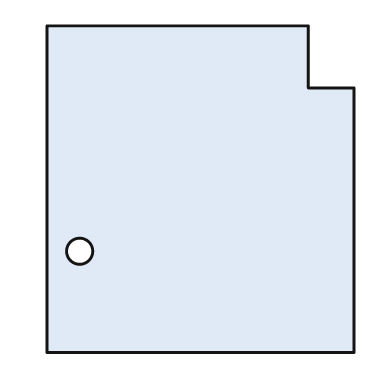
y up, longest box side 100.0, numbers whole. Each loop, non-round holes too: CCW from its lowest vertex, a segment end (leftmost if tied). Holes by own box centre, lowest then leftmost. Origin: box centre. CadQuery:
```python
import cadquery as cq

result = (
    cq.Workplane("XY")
    .moveTo(-47.0, -50.0)
    .lineTo(47.0, -50.0)
    .lineTo(47.0, 31.0)
    .lineTo(33.0, 31.0)
    .lineTo(33.0, 50.0)
    .lineTo(-47.0, 50.0)
    .close()
    .moveTo(-37.0, -19.0)
    .circle(4.0)
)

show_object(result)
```